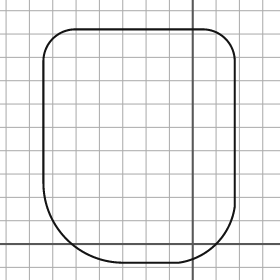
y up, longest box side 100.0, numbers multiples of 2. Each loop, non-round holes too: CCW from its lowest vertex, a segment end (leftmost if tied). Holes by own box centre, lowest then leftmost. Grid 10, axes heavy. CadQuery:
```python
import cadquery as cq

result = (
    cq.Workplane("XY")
    .moveTo(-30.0, -8.0)
    .lineTo(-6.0, -8.0)
    .threePointArc((10.0, 0.0), (18.0, 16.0))
    .lineTo(18.0, 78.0)
    .threePointArc((14.0, 88.0), (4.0, 92.0))
    .lineTo(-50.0, 92.0)
    .threePointArc((-60.0, 88.0), (-64.0, 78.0))
    .lineTo(-64.0, 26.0)
    .threePointArc((-54.0, 2.0), (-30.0, -8.0))
    .close()
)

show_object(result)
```